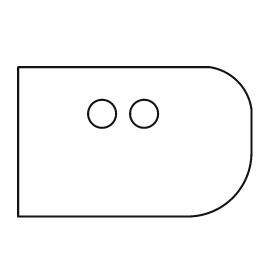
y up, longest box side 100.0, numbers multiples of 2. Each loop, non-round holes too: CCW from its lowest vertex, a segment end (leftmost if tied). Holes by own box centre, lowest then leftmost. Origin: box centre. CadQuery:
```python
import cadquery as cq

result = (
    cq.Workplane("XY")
    .moveTo(-50.0, -32.0)
    .lineTo(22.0, -32.0)
    .threePointArc((42.0, -24.0), (50.0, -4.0))
    .lineTo(50.0, 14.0)
    .threePointArc((44.0, 26.0), (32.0, 32.0))
    .lineTo(-50.0, 32.0)
    .close()
    .moveTo(-14.0, 12.0)
    .circle(6.0)
    .moveTo(4.0, 12.0)
    .circle(6.0)
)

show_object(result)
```